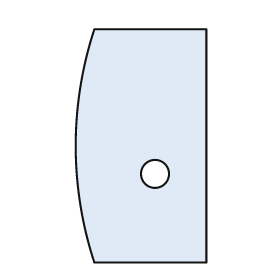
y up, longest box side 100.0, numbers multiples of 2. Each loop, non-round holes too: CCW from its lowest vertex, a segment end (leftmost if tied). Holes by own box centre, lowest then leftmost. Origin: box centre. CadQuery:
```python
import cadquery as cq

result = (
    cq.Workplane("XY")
    .moveTo(-20.0, -50.0)
    .lineTo(28.0, -50.0)
    .lineTo(28.0, 50.0)
    .lineTo(-20.0, 50.0)
    .threePointArc((-28.0, 0.0), (-20.0, -50.0))
    .close()
    .moveTo(6.0, -12.0)
    .circle(6.0)
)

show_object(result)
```